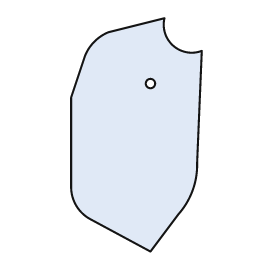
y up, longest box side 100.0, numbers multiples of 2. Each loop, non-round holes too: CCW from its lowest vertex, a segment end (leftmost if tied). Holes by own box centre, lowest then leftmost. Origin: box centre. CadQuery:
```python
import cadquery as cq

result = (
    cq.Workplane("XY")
    .moveTo(6.0, -50.0)
    .lineTo(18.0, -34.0)
    .threePointArc((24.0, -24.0), (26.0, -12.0))
    .lineTo(28.0, 36.0)
    .threePointArc((16.0, 38.0), (12.0, 50.0))
    .lineTo(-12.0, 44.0)
    .threePointArc((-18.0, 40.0), (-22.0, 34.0))
    .lineTo(-28.0, 16.0)
    .lineTo(-28.0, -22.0)
    .threePointArc((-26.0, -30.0), (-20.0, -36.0))
    .close()
    .moveTo(6.0, 22.0)
    .circle(2.0)
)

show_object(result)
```